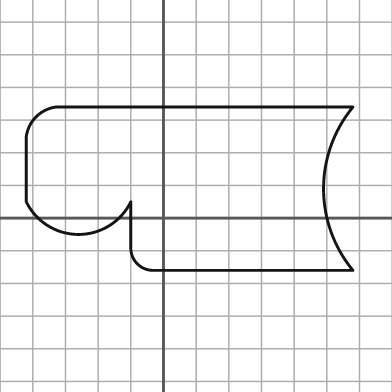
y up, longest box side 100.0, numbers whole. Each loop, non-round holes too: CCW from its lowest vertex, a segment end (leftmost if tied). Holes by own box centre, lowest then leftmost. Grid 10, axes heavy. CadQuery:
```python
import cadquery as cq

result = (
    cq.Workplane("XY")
    .moveTo(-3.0, -16.0)
    .lineTo(58.0, -16.0)
    .threePointArc((49.0, 9.0), (58.0, 34.0))
    .lineTo(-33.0, 34.0)
    .threePointArc((-39.0, 31.0), (-42.0, 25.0))
    .lineTo(-42.0, 5.0)
    .threePointArc((-26.0, -5.0), (-10.0, 5.0))
    .lineTo(-10.0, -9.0)
    .threePointArc((-8.0, -14.0), (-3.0, -16.0))
    .close()
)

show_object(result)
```